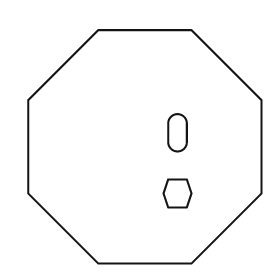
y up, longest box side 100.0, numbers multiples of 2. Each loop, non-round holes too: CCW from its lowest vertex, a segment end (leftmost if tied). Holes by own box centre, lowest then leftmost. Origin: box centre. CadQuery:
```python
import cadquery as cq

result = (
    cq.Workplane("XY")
    .moveTo(-20.0, -50.0)
    .lineTo(20.0, -50.0)
    .lineTo(50.0, -20.0)
    .lineTo(50.0, 20.0)
    .lineTo(20.0, 50.0)
    .lineTo(-20.0, 50.0)
    .lineTo(-50.0, 20.0)
    .lineTo(-50.0, -20.0)
    .close()
    .moveTo(10.0, -26.0)
    .lineTo(18.0, -26.0)
    .lineTo(20.0, -20.0)
    .lineTo(18.0, -14.0)
    .lineTo(10.0, -14.0)
    .lineTo(8.0, -20.0)
    .close()
    .moveTo(10.0, 2.0)
    .threePointArc((14.0, -2.0), (18.0, 2.0))
    .lineTo(18.0, 10.0)
    .threePointArc((14.0, 14.0), (10.0, 10.0))
    .close()
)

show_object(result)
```